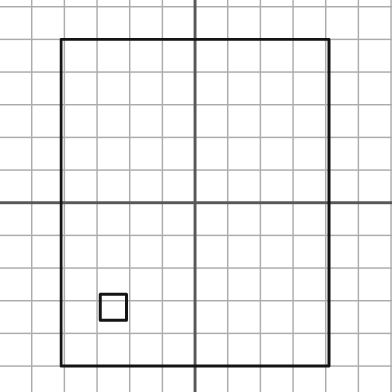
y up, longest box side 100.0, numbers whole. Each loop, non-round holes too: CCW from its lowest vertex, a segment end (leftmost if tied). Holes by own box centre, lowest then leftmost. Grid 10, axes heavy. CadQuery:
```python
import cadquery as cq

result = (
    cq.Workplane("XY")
    .moveTo(-41.0, -50.0)
    .lineTo(41.0, -50.0)
    .lineTo(41.0, 50.0)
    .lineTo(-41.0, 50.0)
    .close()
    .moveTo(-29.0, -36.0)
    .lineTo(-21.0, -36.0)
    .lineTo(-21.0, -28.0)
    .lineTo(-29.0, -28.0)
    .close()
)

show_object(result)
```